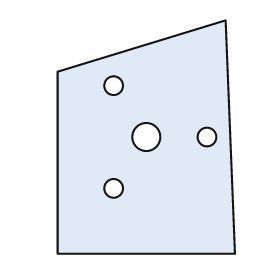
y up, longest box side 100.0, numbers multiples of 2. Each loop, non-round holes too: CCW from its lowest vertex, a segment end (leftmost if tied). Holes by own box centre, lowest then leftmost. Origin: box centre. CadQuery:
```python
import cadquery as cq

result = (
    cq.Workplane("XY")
    .moveTo(-38.0, -50.0)
    .lineTo(38.0, -50.0)
    .lineTo(34.0, 50.0)
    .lineTo(-38.0, 28.0)
    .close()
    .moveTo(-14.0, -22.0)
    .circle(4.0)
    .moveTo(0.0, 0.0)
    .circle(6.0)
    .moveTo(26.0, 0.0)
    .circle(4.0)
    .moveTo(-14.0, 22.0)
    .circle(4.0)
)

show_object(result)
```